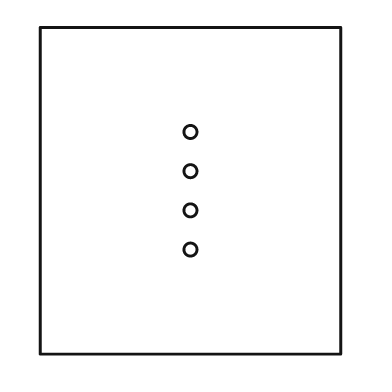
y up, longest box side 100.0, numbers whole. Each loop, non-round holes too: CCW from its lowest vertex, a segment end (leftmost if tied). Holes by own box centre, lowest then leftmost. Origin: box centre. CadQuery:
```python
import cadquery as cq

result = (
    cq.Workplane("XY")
    .moveTo(-46.0, -50.0)
    .lineTo(46.0, -50.0)
    .lineTo(46.0, 50.0)
    .lineTo(-46.0, 50.0)
    .close()
    .moveTo(0.0, -18.0)
    .circle(2.0)
    .moveTo(0.0, -6.0)
    .circle(2.0)
    .moveTo(0.0, 6.0)
    .circle(2.0)
    .moveTo(0.0, 18.0)
    .circle(2.0)
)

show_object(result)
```